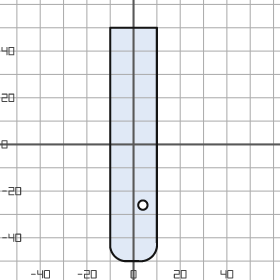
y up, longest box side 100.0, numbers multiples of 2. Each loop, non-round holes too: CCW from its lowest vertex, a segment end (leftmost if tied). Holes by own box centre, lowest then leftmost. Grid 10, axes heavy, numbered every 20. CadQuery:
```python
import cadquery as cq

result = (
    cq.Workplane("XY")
    .moveTo(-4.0, -50.0)
    .lineTo(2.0, -50.0)
    .threePointArc((8.0, -48.0), (10.0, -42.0))
    .lineTo(10.0, 50.0)
    .lineTo(-10.0, 50.0)
    .lineTo(-10.0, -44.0)
    .threePointArc((-8.0, -48.0), (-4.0, -50.0))
    .close()
    .moveTo(4.0, -26.0)
    .circle(2.0)
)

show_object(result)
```